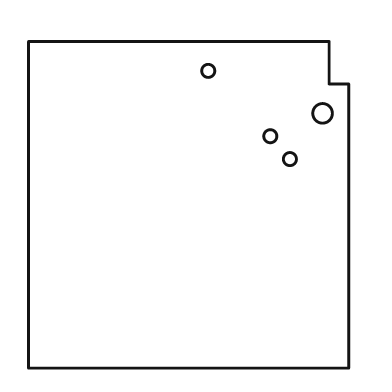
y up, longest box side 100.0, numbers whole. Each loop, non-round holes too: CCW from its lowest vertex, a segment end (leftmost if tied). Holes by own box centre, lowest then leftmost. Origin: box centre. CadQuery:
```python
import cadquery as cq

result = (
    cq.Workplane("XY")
    .moveTo(-49.0, -50.0)
    .lineTo(49.0, -50.0)
    .lineTo(49.0, 37.0)
    .lineTo(43.0, 37.0)
    .lineTo(43.0, 50.0)
    .lineTo(-49.0, 50.0)
    .close()
    .moveTo(31.0, 14.0)
    .circle(2.0)
    .moveTo(25.0, 21.0)
    .circle(2.0)
    .moveTo(41.0, 28.0)
    .circle(3.0)
    .moveTo(6.0, 41.0)
    .circle(2.0)
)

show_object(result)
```